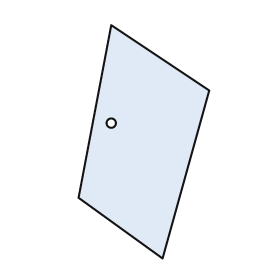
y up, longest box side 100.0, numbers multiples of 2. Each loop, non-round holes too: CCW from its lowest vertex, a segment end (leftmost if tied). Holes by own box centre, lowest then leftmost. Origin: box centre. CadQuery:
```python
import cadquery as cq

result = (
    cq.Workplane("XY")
    .moveTo(8.0, -50.0)
    .lineTo(28.0, 22.0)
    .lineTo(-14.0, 50.0)
    .lineTo(-28.0, -24.0)
    .close()
    .moveTo(-14.0, 8.0)
    .circle(2.0)
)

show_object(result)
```